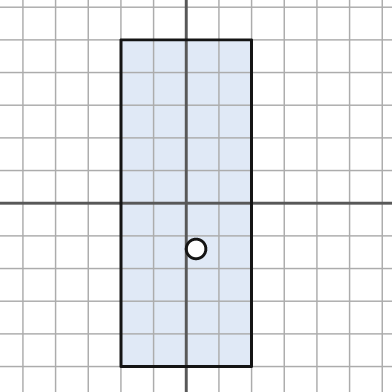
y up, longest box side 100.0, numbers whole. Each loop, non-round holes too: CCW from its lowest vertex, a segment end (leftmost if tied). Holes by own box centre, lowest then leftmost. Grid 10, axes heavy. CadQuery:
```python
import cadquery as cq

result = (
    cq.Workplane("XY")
    .moveTo(-20.0, -50.0)
    .lineTo(20.0, -50.0)
    .lineTo(20.0, 50.0)
    .lineTo(-20.0, 50.0)
    .close()
    .moveTo(3.0, -14.0)
    .circle(3.0)
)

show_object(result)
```